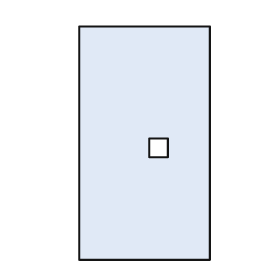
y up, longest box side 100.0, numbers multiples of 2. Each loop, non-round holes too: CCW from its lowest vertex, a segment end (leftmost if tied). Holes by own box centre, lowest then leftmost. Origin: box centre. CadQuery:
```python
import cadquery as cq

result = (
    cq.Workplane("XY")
    .moveTo(-28.0, -50.0)
    .lineTo(28.0, -50.0)
    .lineTo(28.0, 50.0)
    .lineTo(-28.0, 50.0)
    .close()
    .moveTo(2.0, -6.0)
    .lineTo(10.0, -6.0)
    .lineTo(10.0, 2.0)
    .lineTo(2.0, 2.0)
    .close()
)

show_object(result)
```